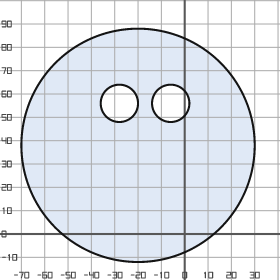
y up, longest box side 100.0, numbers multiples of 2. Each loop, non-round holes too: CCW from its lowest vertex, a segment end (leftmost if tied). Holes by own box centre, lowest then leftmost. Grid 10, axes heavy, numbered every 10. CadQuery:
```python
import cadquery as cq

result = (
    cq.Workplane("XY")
    .moveTo(-20.0, 38.0)
    .circle(50.0)
    .moveTo(-28.0, 56.0)
    .circle(8.0)
    .moveTo(-6.0, 56.0)
    .circle(8.0)
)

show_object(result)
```